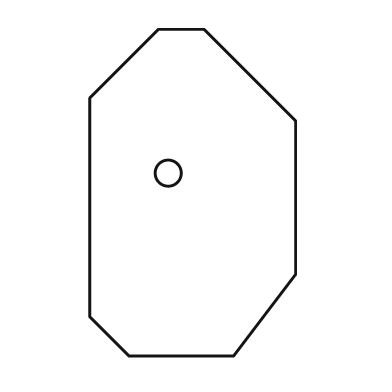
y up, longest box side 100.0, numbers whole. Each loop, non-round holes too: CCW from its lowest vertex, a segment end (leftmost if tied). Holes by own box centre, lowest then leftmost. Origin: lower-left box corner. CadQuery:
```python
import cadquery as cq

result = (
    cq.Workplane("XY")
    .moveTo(12.0, 0.0)
    .lineTo(44.0, 0.0)
    .lineTo(63.0, 25.0)
    .lineTo(63.0, 72.0)
    .lineTo(35.0, 100.0)
    .lineTo(21.0, 100.0)
    .lineTo(0.0, 79.0)
    .lineTo(0.0, 12.0)
    .close()
    .moveTo(24.0, 56.0)
    .circle(4.0)
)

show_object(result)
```